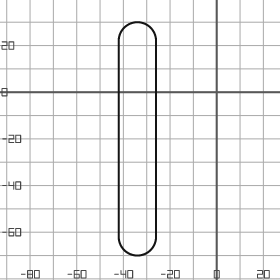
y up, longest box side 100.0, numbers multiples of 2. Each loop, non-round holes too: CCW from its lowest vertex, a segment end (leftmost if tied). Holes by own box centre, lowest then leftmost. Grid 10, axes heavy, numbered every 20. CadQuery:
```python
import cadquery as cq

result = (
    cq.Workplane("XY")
    .moveTo(-42.0, -62.0)
    .threePointArc((-34.0, -70.0), (-26.0, -62.0))
    .lineTo(-26.0, 22.0)
    .threePointArc((-34.0, 30.0), (-42.0, 22.0))
    .close()
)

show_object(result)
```